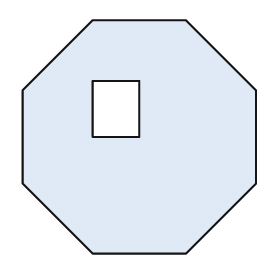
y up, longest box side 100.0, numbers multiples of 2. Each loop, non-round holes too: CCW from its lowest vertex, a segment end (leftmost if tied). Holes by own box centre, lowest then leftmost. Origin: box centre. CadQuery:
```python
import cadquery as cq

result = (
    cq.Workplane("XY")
    .moveTo(-20.0, -50.0)
    .lineTo(20.0, -50.0)
    .lineTo(50.0, -20.0)
    .lineTo(50.0, 20.0)
    .lineTo(20.0, 50.0)
    .lineTo(-20.0, 50.0)
    .lineTo(-50.0, 20.0)
    .lineTo(-50.0, -20.0)
    .close()
    .moveTo(-20.0, 0.0)
    .lineTo(0.0, 0.0)
    .lineTo(0.0, 24.0)
    .lineTo(-20.0, 24.0)
    .close()
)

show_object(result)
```